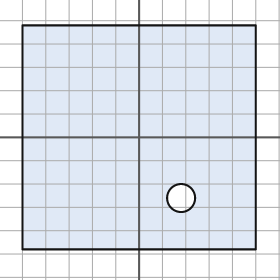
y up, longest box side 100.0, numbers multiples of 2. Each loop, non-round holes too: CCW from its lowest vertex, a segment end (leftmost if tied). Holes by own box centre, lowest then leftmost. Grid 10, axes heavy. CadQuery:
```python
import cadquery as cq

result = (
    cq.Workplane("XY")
    .moveTo(-50.0, -48.0)
    .lineTo(50.0, -48.0)
    .lineTo(50.0, 48.0)
    .lineTo(-50.0, 48.0)
    .close()
    .moveTo(18.0, -26.0)
    .circle(6.0)
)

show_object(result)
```